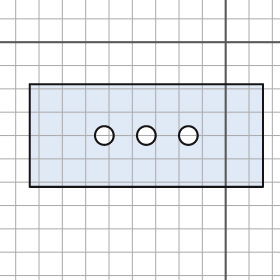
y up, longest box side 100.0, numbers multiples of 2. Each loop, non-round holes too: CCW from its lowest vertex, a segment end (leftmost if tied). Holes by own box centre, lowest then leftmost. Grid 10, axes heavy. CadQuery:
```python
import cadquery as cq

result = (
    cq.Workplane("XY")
    .moveTo(-84.0, -62.0)
    .lineTo(16.0, -62.0)
    .lineTo(16.0, -18.0)
    .lineTo(-84.0, -18.0)
    .close()
    .moveTo(-52.0, -40.0)
    .circle(4.0)
    .moveTo(-34.0, -40.0)
    .circle(4.0)
    .moveTo(-16.0, -40.0)
    .circle(4.0)
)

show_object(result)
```